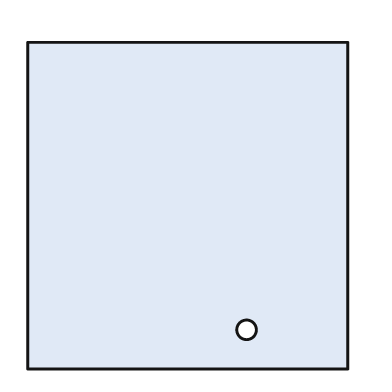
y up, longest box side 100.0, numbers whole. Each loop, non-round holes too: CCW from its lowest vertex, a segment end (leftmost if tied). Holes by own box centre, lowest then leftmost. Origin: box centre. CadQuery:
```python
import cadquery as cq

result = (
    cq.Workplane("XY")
    .moveTo(-49.0, -50.0)
    .lineTo(49.0, -50.0)
    .lineTo(49.0, 50.0)
    .lineTo(-49.0, 50.0)
    .close()
    .moveTo(18.0, -38.0)
    .circle(3.0)
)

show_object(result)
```